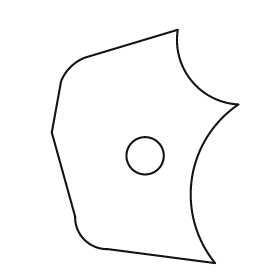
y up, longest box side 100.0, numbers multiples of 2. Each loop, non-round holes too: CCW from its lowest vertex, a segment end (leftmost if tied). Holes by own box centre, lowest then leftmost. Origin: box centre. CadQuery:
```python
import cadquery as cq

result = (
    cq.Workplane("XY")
    .moveTo(30.0, -50.0)
    .threePointArc((20.0, -14.0), (40.0, 18.0))
    .threePointArc((20.0, 28.0), (14.0, 50.0))
    .lineTo(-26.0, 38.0)
    .threePointArc((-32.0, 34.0), (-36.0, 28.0))
    .lineTo(-40.0, 6.0)
    .lineTo(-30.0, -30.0)
    .threePointArc((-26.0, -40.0), (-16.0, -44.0))
    .close()
    .moveTo(0.0, -4.0)
    .circle(8.0)
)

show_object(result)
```